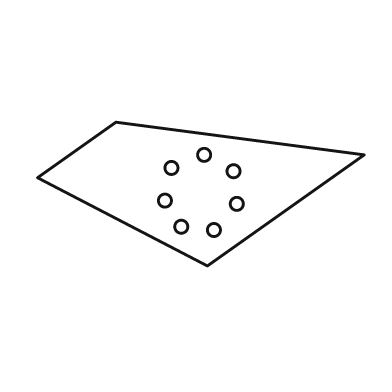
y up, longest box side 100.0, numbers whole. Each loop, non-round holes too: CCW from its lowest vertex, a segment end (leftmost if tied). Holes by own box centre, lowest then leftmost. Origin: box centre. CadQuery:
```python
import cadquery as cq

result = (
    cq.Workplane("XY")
    .moveTo(2.0, -22.0)
    .lineTo(50.0, 12.0)
    .lineTo(-26.0, 22.0)
    .lineTo(-50.0, 5.0)
    .close()
    .moveTo(4.0, -11.0)
    .circle(2.0)
    .moveTo(-6.0, -10.0)
    .circle(2.0)
    .moveTo(11.0, -3.0)
    .circle(2.0)
    .moveTo(-11.0, -2.0)
    .circle(2.0)
    .moveTo(10.0, 7.0)
    .circle(2.0)
    .moveTo(-9.0, 8.0)
    .circle(2.0)
    .moveTo(1.0, 12.0)
    .circle(2.0)
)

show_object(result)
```